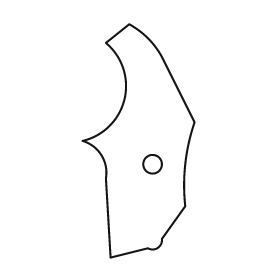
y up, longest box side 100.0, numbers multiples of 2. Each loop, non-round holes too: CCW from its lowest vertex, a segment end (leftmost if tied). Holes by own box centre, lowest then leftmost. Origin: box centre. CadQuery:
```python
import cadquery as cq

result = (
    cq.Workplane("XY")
    .moveTo(-12.0, -50.0)
    .lineTo(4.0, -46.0)
    .threePointArc((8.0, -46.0), (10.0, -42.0))
    .lineTo(20.0, -28.0)
    .threePointArc((20.0, -10.0), (24.0, 8.0))
    .lineTo(10.0, 36.0)
    .threePointArc((4.0, 44.0), (-4.0, 50.0))
    .lineTo(-14.0, 42.0)
    .threePointArc((-6.0, 18.0), (-24.0, 0.0))
    .threePointArc((-16.0, -6.0), (-14.0, -16.0))
    .close()
    .moveTo(6.0, -10.0)
    .circle(4.0)
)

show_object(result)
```